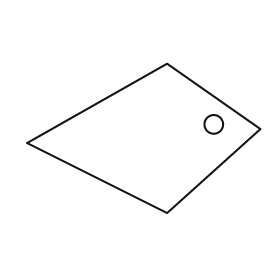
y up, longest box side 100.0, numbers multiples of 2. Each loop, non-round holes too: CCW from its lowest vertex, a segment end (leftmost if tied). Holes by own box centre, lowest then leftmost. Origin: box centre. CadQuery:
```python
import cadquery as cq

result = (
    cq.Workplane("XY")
    .moveTo(10.0, -32.0)
    .lineTo(50.0, 4.0)
    .lineTo(10.0, 32.0)
    .lineTo(-50.0, -2.0)
    .close()
    .moveTo(30.0, 6.0)
    .circle(4.0)
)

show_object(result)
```